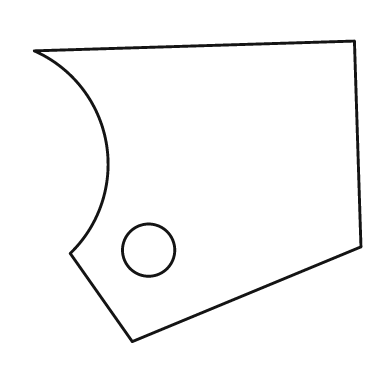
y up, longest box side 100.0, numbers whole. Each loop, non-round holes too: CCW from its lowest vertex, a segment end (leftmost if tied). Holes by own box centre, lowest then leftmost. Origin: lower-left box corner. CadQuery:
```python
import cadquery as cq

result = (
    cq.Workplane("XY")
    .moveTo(30.0, 0.0)
    .lineTo(100.0, 29.0)
    .lineTo(98.0, 92.0)
    .lineTo(0.0, 89.0)
    .threePointArc((22.0, 61.0), (11.0, 27.0))
    .close()
    .moveTo(35.0, 28.0)
    .circle(8.0)
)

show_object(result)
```